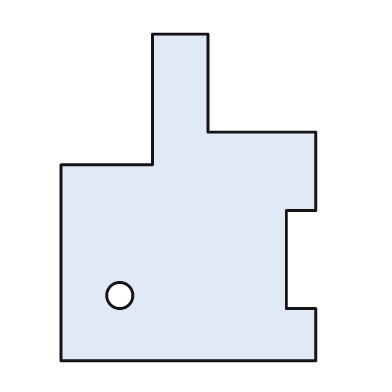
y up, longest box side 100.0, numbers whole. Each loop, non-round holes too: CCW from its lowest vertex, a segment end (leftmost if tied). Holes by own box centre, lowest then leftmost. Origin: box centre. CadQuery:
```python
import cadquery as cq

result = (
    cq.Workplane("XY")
    .moveTo(-39.0, -50.0)
    .lineTo(39.0, -50.0)
    .lineTo(39.0, -34.0)
    .lineTo(30.0, -34.0)
    .lineTo(30.0, -4.0)
    .lineTo(39.0, -4.0)
    .lineTo(39.0, 20.0)
    .lineTo(6.0, 20.0)
    .lineTo(6.0, 50.0)
    .lineTo(-11.0, 50.0)
    .lineTo(-11.0, 10.0)
    .lineTo(-39.0, 10.0)
    .close()
    .moveTo(-21.0, -30.0)
    .circle(4.0)
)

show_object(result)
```